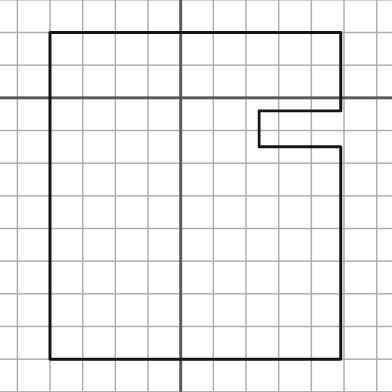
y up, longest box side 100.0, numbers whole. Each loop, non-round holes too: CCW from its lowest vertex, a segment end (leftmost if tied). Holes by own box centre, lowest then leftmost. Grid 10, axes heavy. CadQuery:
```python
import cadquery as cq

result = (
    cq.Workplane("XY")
    .moveTo(-40.0, -80.0)
    .lineTo(49.0, -80.0)
    .lineTo(49.0, -15.0)
    .lineTo(24.0, -15.0)
    .lineTo(24.0, -4.0)
    .lineTo(49.0, -4.0)
    .lineTo(49.0, 20.0)
    .lineTo(-40.0, 20.0)
    .close()
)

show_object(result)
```